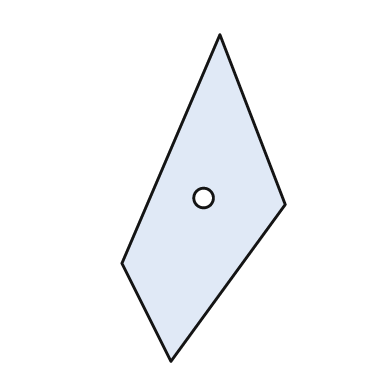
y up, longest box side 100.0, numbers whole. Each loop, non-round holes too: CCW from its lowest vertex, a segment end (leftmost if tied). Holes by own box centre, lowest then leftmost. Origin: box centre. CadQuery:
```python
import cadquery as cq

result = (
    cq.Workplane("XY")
    .moveTo(-10.0, -50.0)
    .lineTo(25.0, -2.0)
    .lineTo(5.0, 50.0)
    .lineTo(-25.0, -20.0)
    .close()
    .moveTo(0.0, 0.0)
    .circle(3.0)
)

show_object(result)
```